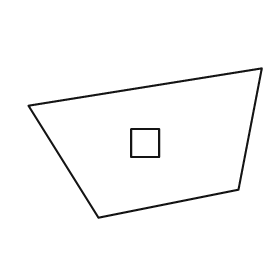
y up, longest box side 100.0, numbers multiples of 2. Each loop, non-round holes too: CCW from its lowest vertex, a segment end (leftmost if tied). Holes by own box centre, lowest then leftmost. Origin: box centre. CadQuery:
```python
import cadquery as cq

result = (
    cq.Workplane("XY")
    .moveTo(-20.0, -32.0)
    .lineTo(40.0, -20.0)
    .lineTo(50.0, 32.0)
    .lineTo(-50.0, 16.0)
    .close()
    .moveTo(-6.0, -6.0)
    .lineTo(6.0, -6.0)
    .lineTo(6.0, 6.0)
    .lineTo(-6.0, 6.0)
    .close()
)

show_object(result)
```